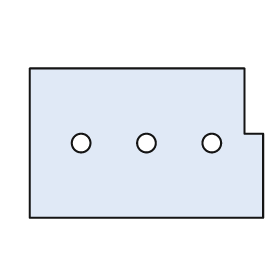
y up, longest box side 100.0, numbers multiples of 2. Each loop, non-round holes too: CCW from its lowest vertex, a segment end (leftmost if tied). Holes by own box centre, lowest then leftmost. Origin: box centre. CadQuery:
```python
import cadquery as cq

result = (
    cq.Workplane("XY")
    .moveTo(-50.0, -32.0)
    .lineTo(50.0, -32.0)
    .lineTo(50.0, 4.0)
    .lineTo(42.0, 4.0)
    .lineTo(42.0, 32.0)
    .lineTo(-50.0, 32.0)
    .close()
    .moveTo(-28.0, 0.0)
    .circle(4.0)
    .moveTo(0.0, 0.0)
    .circle(4.0)
    .moveTo(28.0, 0.0)
    .circle(4.0)
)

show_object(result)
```